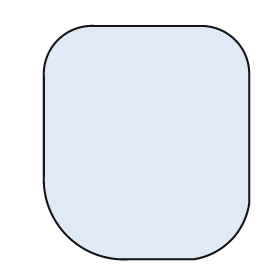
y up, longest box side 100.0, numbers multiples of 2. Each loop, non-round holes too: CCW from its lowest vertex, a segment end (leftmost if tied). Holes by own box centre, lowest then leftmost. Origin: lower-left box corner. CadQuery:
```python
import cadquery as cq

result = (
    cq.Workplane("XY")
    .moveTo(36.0, 0.0)
    .lineTo(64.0, 0.0)
    .threePointArc((80.0, 8.0), (88.0, 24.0))
    .lineTo(88.0, 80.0)
    .threePointArc((82.0, 94.0), (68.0, 100.0))
    .lineTo(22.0, 100.0)
    .threePointArc((6.0, 94.0), (0.0, 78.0))
    .lineTo(0.0, 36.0)
    .threePointArc((10.0, 10.0), (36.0, 0.0))
    .close()
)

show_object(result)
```